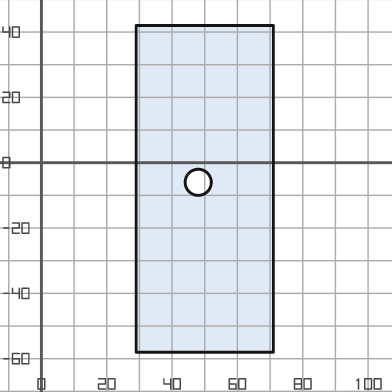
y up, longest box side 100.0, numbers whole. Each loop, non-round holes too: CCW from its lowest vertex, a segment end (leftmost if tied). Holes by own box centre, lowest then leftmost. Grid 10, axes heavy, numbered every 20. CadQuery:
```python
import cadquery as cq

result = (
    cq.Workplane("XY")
    .moveTo(29.0, -58.0)
    .lineTo(71.0, -58.0)
    .lineTo(71.0, 42.0)
    .lineTo(29.0, 42.0)
    .close()
    .moveTo(48.0, -6.0)
    .circle(4.0)
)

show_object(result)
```